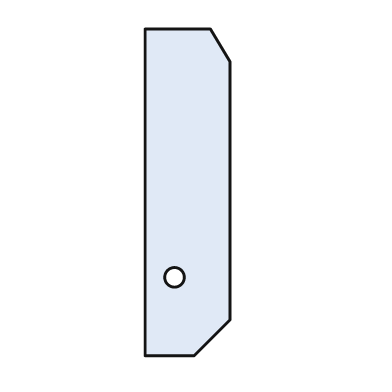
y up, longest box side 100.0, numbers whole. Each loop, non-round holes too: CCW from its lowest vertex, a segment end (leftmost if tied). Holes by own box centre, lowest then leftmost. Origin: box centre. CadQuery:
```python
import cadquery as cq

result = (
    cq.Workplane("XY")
    .moveTo(-13.0, -50.0)
    .lineTo(2.0, -50.0)
    .lineTo(13.0, -39.0)
    .lineTo(13.0, 40.0)
    .lineTo(7.0, 50.0)
    .lineTo(-13.0, 50.0)
    .close()
    .moveTo(-4.0, -26.0)
    .circle(3.0)
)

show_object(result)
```